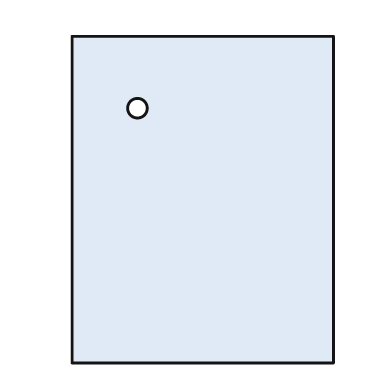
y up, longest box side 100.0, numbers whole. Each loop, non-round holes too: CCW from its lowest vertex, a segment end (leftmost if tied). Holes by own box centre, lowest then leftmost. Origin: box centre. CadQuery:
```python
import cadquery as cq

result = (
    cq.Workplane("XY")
    .moveTo(-40.0, -50.0)
    .lineTo(40.0, -50.0)
    .lineTo(40.0, 50.0)
    .lineTo(-40.0, 50.0)
    .close()
    .moveTo(-20.0, 28.0)
    .circle(3.0)
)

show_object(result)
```